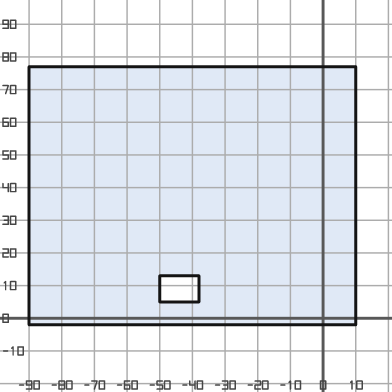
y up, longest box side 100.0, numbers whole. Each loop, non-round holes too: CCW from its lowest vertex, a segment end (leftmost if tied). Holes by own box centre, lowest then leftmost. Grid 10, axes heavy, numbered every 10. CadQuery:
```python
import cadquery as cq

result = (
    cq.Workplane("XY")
    .moveTo(-90.0, -2.0)
    .lineTo(10.0, -2.0)
    .lineTo(10.0, 77.0)
    .lineTo(-90.0, 77.0)
    .close()
    .moveTo(-50.0, 5.0)
    .lineTo(-38.0, 5.0)
    .lineTo(-38.0, 13.0)
    .lineTo(-50.0, 13.0)
    .close()
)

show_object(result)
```